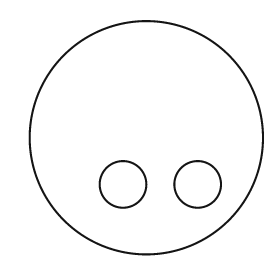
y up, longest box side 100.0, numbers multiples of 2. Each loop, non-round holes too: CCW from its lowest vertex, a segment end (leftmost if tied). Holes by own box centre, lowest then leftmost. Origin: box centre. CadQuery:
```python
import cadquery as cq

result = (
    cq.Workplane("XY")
    .moveTo(0.0, 0.0)
    .circle(50.0)
    .moveTo(-10.0, -20.0)
    .circle(10.0)
    .moveTo(22.0, -20.0)
    .circle(10.0)
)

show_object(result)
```